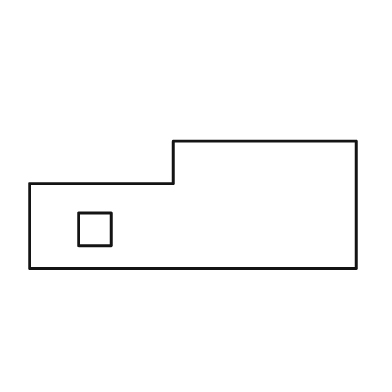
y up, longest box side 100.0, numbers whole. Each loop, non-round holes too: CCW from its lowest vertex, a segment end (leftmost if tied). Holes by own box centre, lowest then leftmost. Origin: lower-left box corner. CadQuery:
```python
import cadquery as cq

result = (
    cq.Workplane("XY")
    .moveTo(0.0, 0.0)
    .lineTo(100.0, 0.0)
    .lineTo(100.0, 39.0)
    .lineTo(44.0, 39.0)
    .lineTo(44.0, 26.0)
    .lineTo(0.0, 26.0)
    .close()
    .moveTo(15.0, 7.0)
    .lineTo(25.0, 7.0)
    .lineTo(25.0, 17.0)
    .lineTo(15.0, 17.0)
    .close()
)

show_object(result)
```